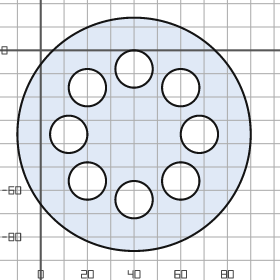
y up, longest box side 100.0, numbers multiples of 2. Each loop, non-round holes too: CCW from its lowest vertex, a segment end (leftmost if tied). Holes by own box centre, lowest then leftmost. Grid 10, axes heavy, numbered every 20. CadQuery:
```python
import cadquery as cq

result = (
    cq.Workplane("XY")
    .moveTo(40.0, -36.0)
    .circle(50.0)
    .moveTo(40.0, -64.0)
    .circle(8.0)
    .moveTo(20.0, -56.0)
    .circle(8.0)
    .moveTo(60.0, -56.0)
    .circle(8.0)
    .moveTo(12.0, -36.0)
    .circle(8.0)
    .moveTo(68.0, -36.0)
    .circle(8.0)
    .moveTo(20.0, -16.0)
    .circle(8.0)
    .moveTo(60.0, -16.0)
    .circle(8.0)
    .moveTo(40.0, -8.0)
    .circle(8.0)
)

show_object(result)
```